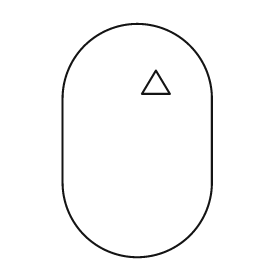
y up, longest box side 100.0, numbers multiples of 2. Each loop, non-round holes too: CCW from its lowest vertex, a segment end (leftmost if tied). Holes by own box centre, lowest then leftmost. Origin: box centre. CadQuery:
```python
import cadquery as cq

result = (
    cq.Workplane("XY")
    .moveTo(-32.0, -18.0)
    .threePointArc((0.0, -50.0), (32.0, -18.0))
    .lineTo(32.0, 18.0)
    .threePointArc((0.0, 50.0), (-32.0, 18.0))
    .close()
    .moveTo(2.0, 20.0)
    .lineTo(14.0, 20.0)
    .lineTo(8.0, 30.0)
    .close()
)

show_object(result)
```